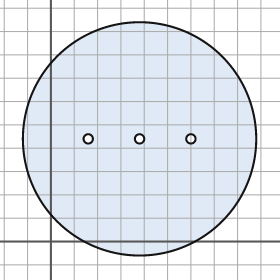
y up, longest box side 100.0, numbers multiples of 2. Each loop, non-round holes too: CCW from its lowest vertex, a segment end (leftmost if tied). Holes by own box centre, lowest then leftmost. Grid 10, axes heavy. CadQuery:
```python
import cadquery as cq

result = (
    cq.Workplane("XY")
    .moveTo(38.0, 44.0)
    .circle(50.0)
    .moveTo(16.0, 44.0)
    .circle(2.0)
    .moveTo(38.0, 44.0)
    .circle(2.0)
    .moveTo(60.0, 44.0)
    .circle(2.0)
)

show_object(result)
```